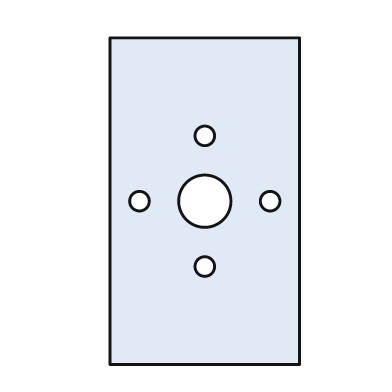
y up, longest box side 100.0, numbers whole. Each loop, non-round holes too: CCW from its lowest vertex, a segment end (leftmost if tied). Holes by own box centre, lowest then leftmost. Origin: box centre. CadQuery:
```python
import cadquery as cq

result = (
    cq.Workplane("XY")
    .moveTo(-29.0, -50.0)
    .lineTo(29.0, -50.0)
    .lineTo(29.0, 50.0)
    .lineTo(-29.0, 50.0)
    .close()
    .moveTo(0.0, -20.0)
    .circle(3.0)
    .moveTo(-20.0, 0.0)
    .circle(3.0)
    .moveTo(0.0, 0.0)
    .circle(8.0)
    .moveTo(20.0, 0.0)
    .circle(3.0)
    .moveTo(0.0, 20.0)
    .circle(3.0)
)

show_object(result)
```